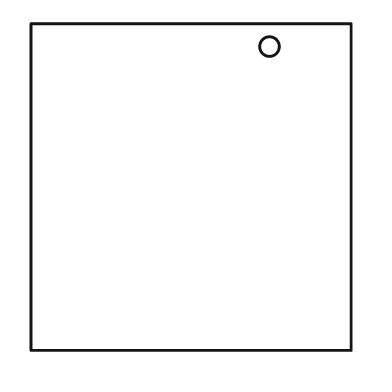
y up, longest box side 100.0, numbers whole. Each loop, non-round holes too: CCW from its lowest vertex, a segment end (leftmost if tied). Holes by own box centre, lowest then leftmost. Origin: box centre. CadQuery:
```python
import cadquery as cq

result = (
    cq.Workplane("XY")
    .moveTo(-49.0, -50.0)
    .lineTo(49.0, -50.0)
    .lineTo(49.0, 50.0)
    .lineTo(-49.0, 50.0)
    .close()
    .moveTo(24.0, 43.0)
    .circle(3.0)
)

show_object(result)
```